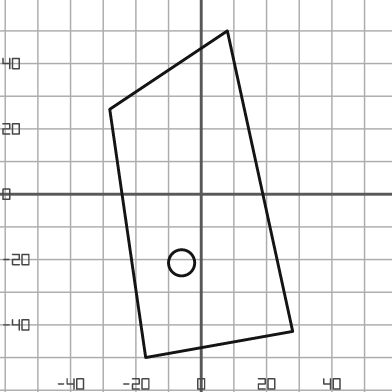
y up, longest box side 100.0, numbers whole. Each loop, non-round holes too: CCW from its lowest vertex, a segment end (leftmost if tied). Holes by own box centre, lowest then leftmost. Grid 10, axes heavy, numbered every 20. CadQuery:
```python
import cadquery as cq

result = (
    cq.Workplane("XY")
    .moveTo(-17.0, -50.0)
    .lineTo(28.0, -42.0)
    .lineTo(8.0, 50.0)
    .lineTo(-28.0, 26.0)
    .close()
    .moveTo(-6.0, -21.0)
    .circle(4.0)
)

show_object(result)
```